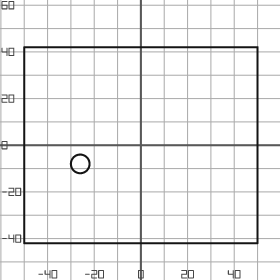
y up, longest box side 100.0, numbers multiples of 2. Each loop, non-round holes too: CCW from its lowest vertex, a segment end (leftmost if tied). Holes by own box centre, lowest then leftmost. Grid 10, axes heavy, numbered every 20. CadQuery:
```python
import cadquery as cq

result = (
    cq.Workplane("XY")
    .moveTo(-50.0, -42.0)
    .lineTo(50.0, -42.0)
    .lineTo(50.0, 42.0)
    .lineTo(-50.0, 42.0)
    .close()
    .moveTo(-26.0, -8.0)
    .circle(4.0)
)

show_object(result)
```